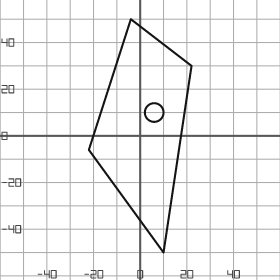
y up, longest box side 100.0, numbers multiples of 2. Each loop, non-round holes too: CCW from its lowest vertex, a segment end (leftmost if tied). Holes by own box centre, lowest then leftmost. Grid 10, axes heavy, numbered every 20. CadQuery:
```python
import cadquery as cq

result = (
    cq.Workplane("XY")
    .moveTo(10.0, -50.0)
    .lineTo(22.0, 30.0)
    .lineTo(-4.0, 50.0)
    .lineTo(-22.0, -6.0)
    .close()
    .moveTo(6.0, 10.0)
    .circle(4.0)
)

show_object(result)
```